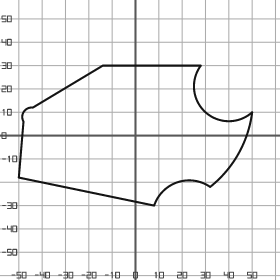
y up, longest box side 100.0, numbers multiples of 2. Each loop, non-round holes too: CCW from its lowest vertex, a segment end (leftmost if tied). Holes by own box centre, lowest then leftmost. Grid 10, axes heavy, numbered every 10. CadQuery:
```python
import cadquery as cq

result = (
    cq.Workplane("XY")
    .moveTo(8.0, -30.0)
    .threePointArc((18.0, -20.0), (32.0, -22.0))
    .threePointArc((44.0, -8.0), (50.0, 10.0))
    .threePointArc((30.0, 10.0), (28.0, 30.0))
    .lineTo(-14.0, 30.0)
    .lineTo(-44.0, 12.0)
    .threePointArc((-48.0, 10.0), (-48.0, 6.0))
    .lineTo(-50.0, -18.0)
    .close()
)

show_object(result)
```